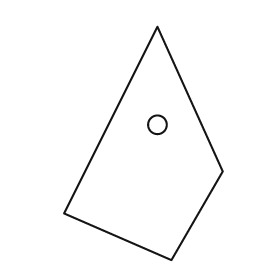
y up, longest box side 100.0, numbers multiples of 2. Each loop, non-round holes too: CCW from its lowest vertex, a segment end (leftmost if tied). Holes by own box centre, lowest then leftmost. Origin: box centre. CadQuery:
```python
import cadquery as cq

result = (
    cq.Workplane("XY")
    .moveTo(12.0, -50.0)
    .lineTo(34.0, -12.0)
    .lineTo(6.0, 50.0)
    .lineTo(-34.0, -30.0)
    .close()
    .moveTo(6.0, 8.0)
    .circle(4.0)
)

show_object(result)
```